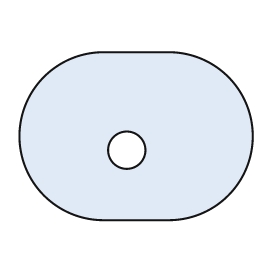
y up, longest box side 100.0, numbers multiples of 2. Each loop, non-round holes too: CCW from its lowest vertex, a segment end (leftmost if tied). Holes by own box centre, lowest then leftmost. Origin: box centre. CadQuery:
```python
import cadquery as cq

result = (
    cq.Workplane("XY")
    .moveTo(-14.0, -36.0)
    .lineTo(14.0, -36.0)
    .threePointArc((50.0, 0.0), (14.0, 36.0))
    .lineTo(-14.0, 36.0)
    .threePointArc((-50.0, 0.0), (-14.0, -36.0))
    .close()
    .moveTo(-4.0, -6.0)
    .circle(8.0)
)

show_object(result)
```